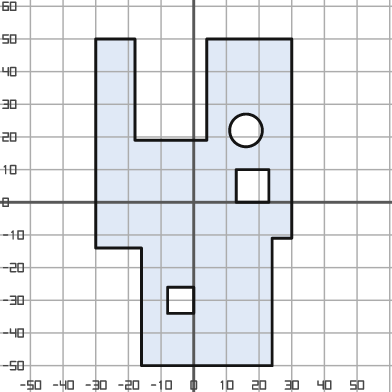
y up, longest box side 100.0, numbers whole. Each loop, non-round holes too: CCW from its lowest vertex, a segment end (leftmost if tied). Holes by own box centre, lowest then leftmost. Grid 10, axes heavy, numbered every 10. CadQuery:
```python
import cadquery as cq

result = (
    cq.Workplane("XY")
    .moveTo(-16.0, -50.0)
    .lineTo(24.0, -50.0)
    .lineTo(24.0, -11.0)
    .lineTo(30.0, -11.0)
    .lineTo(30.0, 50.0)
    .lineTo(4.0, 50.0)
    .lineTo(4.0, 19.0)
    .lineTo(-18.0, 19.0)
    .lineTo(-18.0, 50.0)
    .lineTo(-30.0, 50.0)
    .lineTo(-30.0, -14.0)
    .lineTo(-16.0, -14.0)
    .close()
    .moveTo(-8.0, -34.0)
    .lineTo(0.0, -34.0)
    .lineTo(0.0, -26.0)
    .lineTo(-8.0, -26.0)
    .close()
    .moveTo(13.0, 0.0)
    .lineTo(23.0, 0.0)
    .lineTo(23.0, 10.0)
    .lineTo(13.0, 10.0)
    .close()
    .moveTo(16.0, 22.0)
    .circle(5.0)
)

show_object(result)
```